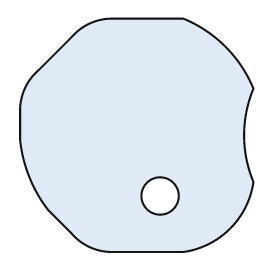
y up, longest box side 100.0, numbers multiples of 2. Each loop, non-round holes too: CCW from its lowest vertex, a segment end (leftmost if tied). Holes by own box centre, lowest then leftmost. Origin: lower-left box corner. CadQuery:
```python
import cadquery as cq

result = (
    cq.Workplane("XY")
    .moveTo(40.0, 0.0)
    .lineTo(70.0, 0.0)
    .threePointArc((90.0, 10.0), (100.0, 30.0))
    .threePointArc((96.0, 50.0), (100.0, 70.0))
    .threePointArc((88.0, 88.0), (70.0, 100.0))
    .lineTo(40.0, 100.0)
    .threePointArc((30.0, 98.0), (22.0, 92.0))
    .lineTo(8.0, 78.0)
    .threePointArc((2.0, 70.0), (0.0, 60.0))
    .lineTo(0.0, 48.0)
    .threePointArc((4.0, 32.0), (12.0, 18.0))
    .lineTo(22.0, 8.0)
    .threePointArc((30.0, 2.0), (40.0, 0.0))
    .close()
    .moveTo(60.0, 24.0)
    .circle(8.0)
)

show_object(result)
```